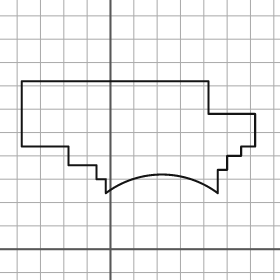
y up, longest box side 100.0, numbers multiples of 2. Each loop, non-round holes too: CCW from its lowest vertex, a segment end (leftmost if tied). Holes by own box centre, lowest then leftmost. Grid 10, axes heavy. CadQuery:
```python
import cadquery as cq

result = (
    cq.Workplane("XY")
    .moveTo(-2.0, 24.0)
    .threePointArc((22.0, 32.0), (46.0, 24.0))
    .lineTo(46.0, 34.0)
    .lineTo(50.0, 34.0)
    .lineTo(50.0, 40.0)
    .lineTo(56.0, 40.0)
    .lineTo(56.0, 44.0)
    .lineTo(62.0, 44.0)
    .lineTo(62.0, 58.0)
    .lineTo(42.0, 58.0)
    .lineTo(42.0, 72.0)
    .lineTo(-38.0, 72.0)
    .lineTo(-38.0, 44.0)
    .lineTo(-18.0, 44.0)
    .lineTo(-18.0, 36.0)
    .lineTo(-6.0, 36.0)
    .lineTo(-6.0, 30.0)
    .lineTo(-2.0, 30.0)
    .close()
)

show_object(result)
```